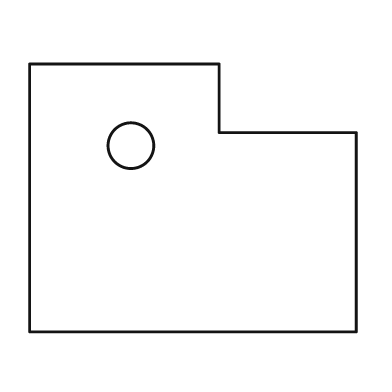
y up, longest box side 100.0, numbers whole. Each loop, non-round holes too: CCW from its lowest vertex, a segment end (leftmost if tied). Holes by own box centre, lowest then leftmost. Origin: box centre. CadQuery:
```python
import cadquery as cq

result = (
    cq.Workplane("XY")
    .moveTo(-50.0, -41.0)
    .lineTo(50.0, -41.0)
    .lineTo(50.0, 20.0)
    .lineTo(8.0, 20.0)
    .lineTo(8.0, 41.0)
    .lineTo(-50.0, 41.0)
    .close()
    .moveTo(-19.0, 16.0)
    .circle(7.0)
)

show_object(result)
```